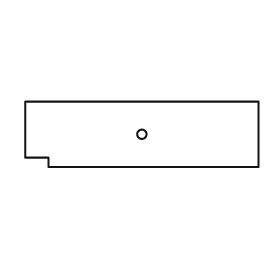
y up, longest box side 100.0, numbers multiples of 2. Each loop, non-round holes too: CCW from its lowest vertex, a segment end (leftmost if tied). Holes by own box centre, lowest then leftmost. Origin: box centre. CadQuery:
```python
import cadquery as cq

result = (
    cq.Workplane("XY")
    .moveTo(-40.0, -14.0)
    .lineTo(50.0, -14.0)
    .lineTo(50.0, 14.0)
    .lineTo(-50.0, 14.0)
    .lineTo(-50.0, -10.0)
    .lineTo(-40.0, -10.0)
    .close()
    .moveTo(0.0, 0.0)
    .circle(2.0)
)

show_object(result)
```